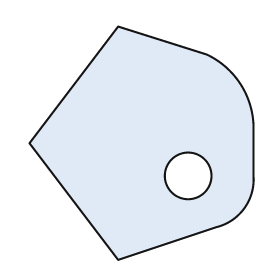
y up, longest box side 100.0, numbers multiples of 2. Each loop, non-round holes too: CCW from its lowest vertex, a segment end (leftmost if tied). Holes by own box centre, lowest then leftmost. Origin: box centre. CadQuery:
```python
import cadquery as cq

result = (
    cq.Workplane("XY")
    .moveTo(-10.0, -50.0)
    .lineTo(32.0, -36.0)
    .threePointArc((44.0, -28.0), (48.0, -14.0))
    .lineTo(48.0, 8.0)
    .threePointArc((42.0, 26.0), (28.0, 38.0))
    .lineTo(-10.0, 50.0)
    .lineTo(-48.0, 0.0)
    .close()
    .moveTo(20.0, -14.0)
    .circle(10.0)
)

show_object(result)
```